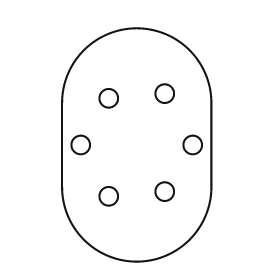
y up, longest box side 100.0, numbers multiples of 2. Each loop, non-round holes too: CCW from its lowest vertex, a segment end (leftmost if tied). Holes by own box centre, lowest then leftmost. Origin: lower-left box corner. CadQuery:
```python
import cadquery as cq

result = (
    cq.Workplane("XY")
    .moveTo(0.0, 32.0)
    .threePointArc((32.0, 0.0), (64.0, 32.0))
    .lineTo(64.0, 68.0)
    .threePointArc((32.0, 100.0), (0.0, 68.0))
    .close()
    .moveTo(20.0, 28.0)
    .circle(4.0)
    .moveTo(44.0, 30.0)
    .circle(4.0)
    .moveTo(8.0, 50.0)
    .circle(4.0)
    .moveTo(56.0, 50.0)
    .circle(4.0)
    .moveTo(20.0, 70.0)
    .circle(4.0)
    .moveTo(44.0, 72.0)
    .circle(4.0)
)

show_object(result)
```